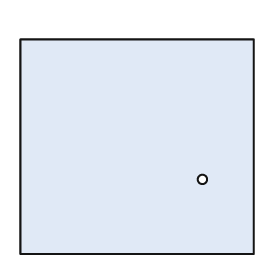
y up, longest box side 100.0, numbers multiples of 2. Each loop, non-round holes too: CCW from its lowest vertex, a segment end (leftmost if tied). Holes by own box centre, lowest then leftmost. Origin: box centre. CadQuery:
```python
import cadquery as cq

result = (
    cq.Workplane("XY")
    .moveTo(-50.0, -46.0)
    .lineTo(50.0, -46.0)
    .lineTo(50.0, 46.0)
    .lineTo(-50.0, 46.0)
    .close()
    .moveTo(28.0, -14.0)
    .circle(2.0)
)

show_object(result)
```